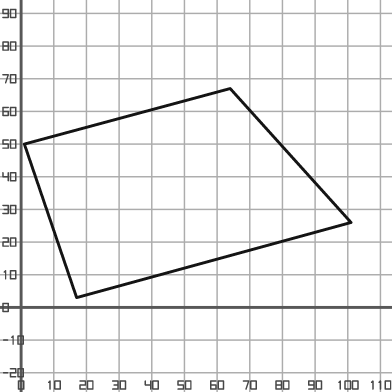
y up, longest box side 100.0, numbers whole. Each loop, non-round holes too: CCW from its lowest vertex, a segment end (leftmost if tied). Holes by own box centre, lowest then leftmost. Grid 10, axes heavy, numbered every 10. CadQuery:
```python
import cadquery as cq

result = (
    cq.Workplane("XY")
    .moveTo(17.0, 3.0)
    .lineTo(101.0, 26.0)
    .lineTo(64.0, 67.0)
    .lineTo(1.0, 50.0)
    .close()
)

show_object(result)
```